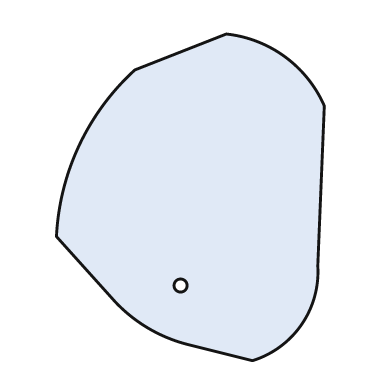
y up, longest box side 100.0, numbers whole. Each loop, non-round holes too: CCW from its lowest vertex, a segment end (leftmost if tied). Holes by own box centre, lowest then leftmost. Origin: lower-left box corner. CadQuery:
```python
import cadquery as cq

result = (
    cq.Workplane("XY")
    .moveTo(60.0, 0.0)
    .threePointArc((75.0, 11.0), (80.0, 29.0))
    .lineTo(82.0, 78.0)
    .threePointArc((70.0, 93.0), (52.0, 100.0))
    .lineTo(24.0, 89.0)
    .threePointArc((7.0, 66.0), (0.0, 38.0))
    .lineTo(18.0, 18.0)
    .threePointArc((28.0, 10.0), (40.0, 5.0))
    .close()
    .moveTo(38.0, 23.0)
    .circle(2.0)
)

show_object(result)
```